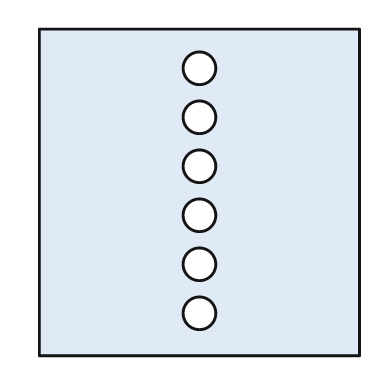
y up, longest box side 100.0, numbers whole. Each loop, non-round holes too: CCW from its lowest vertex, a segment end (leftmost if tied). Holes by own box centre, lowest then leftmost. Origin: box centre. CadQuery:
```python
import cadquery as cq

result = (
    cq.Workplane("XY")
    .moveTo(-49.0, -50.0)
    .lineTo(49.0, -50.0)
    .lineTo(49.0, 50.0)
    .lineTo(-49.0, 50.0)
    .close()
    .moveTo(0.0, -37.0)
    .circle(5.0)
    .moveTo(0.0, -22.0)
    .circle(5.0)
    .moveTo(0.0, -7.0)
    .circle(5.0)
    .moveTo(0.0, 8.0)
    .circle(5.0)
    .moveTo(0.0, 23.0)
    .circle(5.0)
    .moveTo(0.0, 38.0)
    .circle(5.0)
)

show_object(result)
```